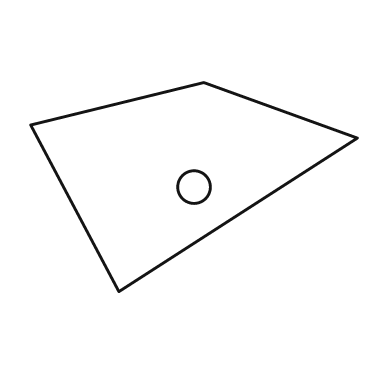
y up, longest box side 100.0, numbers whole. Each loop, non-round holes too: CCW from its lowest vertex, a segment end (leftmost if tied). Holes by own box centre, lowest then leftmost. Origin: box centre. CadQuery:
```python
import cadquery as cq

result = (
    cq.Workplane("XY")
    .moveTo(-23.0, -32.0)
    .lineTo(50.0, 15.0)
    .lineTo(3.0, 32.0)
    .lineTo(-50.0, 19.0)
    .close()
    .moveTo(0.0, 0.0)
    .circle(5.0)
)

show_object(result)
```